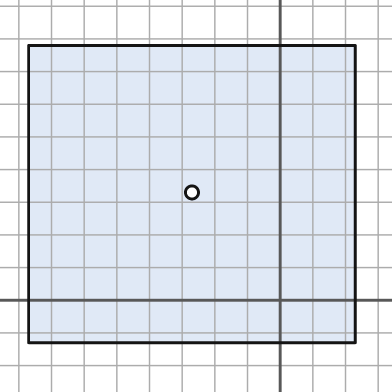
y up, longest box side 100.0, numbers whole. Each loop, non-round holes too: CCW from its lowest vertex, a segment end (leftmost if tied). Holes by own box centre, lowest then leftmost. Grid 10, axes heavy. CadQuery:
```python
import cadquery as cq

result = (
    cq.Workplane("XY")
    .moveTo(-77.0, -13.0)
    .lineTo(23.0, -13.0)
    .lineTo(23.0, 78.0)
    .lineTo(-77.0, 78.0)
    .close()
    .moveTo(-27.0, 33.0)
    .circle(2.0)
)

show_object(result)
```